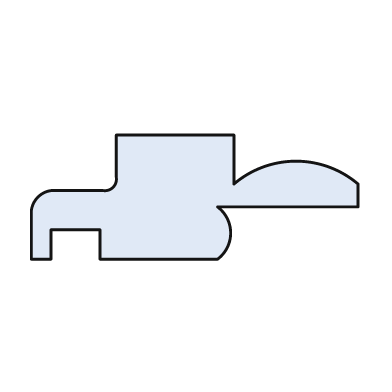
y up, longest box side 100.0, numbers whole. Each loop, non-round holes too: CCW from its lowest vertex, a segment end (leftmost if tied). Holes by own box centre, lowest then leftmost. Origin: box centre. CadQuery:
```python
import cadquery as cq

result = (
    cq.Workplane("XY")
    .moveTo(-50.0, -19.0)
    .lineTo(-44.0, -19.0)
    .lineTo(-44.0, -10.0)
    .lineTo(-29.0, -10.0)
    .lineTo(-29.0, -19.0)
    .lineTo(7.0, -19.0)
    .threePointArc((11.0, -11.0), (7.0, -3.0))
    .lineTo(50.0, -3.0)
    .lineTo(50.0, 4.0)
    .threePointArc((31.0, 11.0), (12.0, 4.0))
    .lineTo(12.0, 19.0)
    .lineTo(-24.0, 19.0)
    .lineTo(-24.0, 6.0)
    .threePointArc((-25.0, 3.0), (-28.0, 2.0))
    .lineTo(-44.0, 2.0)
    .threePointArc((-48.0, 0.0), (-50.0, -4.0))
    .close()
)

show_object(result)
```